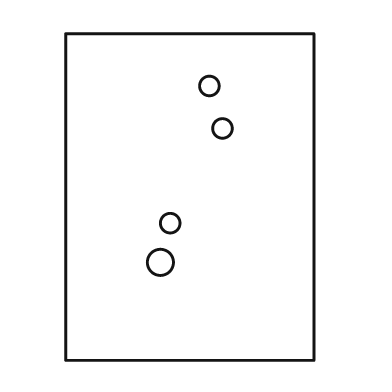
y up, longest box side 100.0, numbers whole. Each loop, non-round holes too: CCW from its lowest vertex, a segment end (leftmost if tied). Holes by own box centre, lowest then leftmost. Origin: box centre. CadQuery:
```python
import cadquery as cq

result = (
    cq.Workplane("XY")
    .moveTo(-38.0, -50.0)
    .lineTo(38.0, -50.0)
    .lineTo(38.0, 50.0)
    .lineTo(-38.0, 50.0)
    .close()
    .moveTo(-9.0, -20.0)
    .circle(4.0)
    .moveTo(-6.0, -8.0)
    .circle(3.0)
    .moveTo(10.0, 21.0)
    .circle(3.0)
    .moveTo(6.0, 34.0)
    .circle(3.0)
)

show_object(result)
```